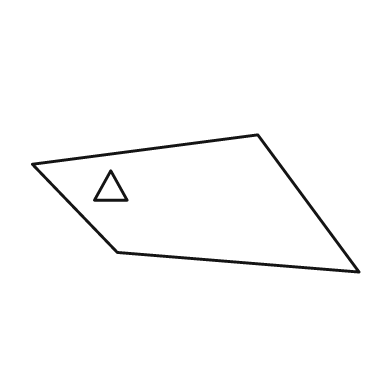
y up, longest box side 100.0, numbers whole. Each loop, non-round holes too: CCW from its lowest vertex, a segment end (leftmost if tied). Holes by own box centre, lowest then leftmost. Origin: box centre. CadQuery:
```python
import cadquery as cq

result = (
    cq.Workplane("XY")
    .moveTo(50.0, -21.0)
    .lineTo(19.0, 21.0)
    .lineTo(-50.0, 12.0)
    .lineTo(-24.0, -15.0)
    .close()
    .moveTo(-31.0, 1.0)
    .lineTo(-21.0, 1.0)
    .lineTo(-26.0, 10.0)
    .close()
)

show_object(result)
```